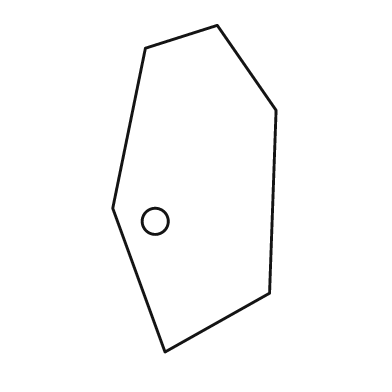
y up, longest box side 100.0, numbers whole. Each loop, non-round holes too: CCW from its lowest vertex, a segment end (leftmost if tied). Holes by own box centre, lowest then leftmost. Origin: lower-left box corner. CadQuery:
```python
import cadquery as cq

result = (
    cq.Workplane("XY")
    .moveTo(16.0, 0.0)
    .lineTo(48.0, 18.0)
    .lineTo(50.0, 74.0)
    .lineTo(32.0, 100.0)
    .lineTo(10.0, 93.0)
    .lineTo(0.0, 44.0)
    .close()
    .moveTo(13.0, 40.0)
    .circle(4.0)
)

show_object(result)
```